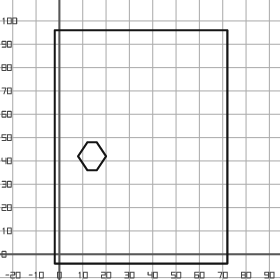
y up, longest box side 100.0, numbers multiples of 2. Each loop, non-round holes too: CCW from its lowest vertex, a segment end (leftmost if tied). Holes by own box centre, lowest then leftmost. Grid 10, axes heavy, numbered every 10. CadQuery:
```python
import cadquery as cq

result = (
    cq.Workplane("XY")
    .moveTo(-2.0, -4.0)
    .lineTo(72.0, -4.0)
    .lineTo(72.0, 96.0)
    .lineTo(-2.0, 96.0)
    .close()
    .moveTo(12.0, 36.0)
    .lineTo(16.0, 36.0)
    .lineTo(20.0, 42.0)
    .lineTo(16.0, 48.0)
    .lineTo(12.0, 48.0)
    .lineTo(8.0, 42.0)
    .close()
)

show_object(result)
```